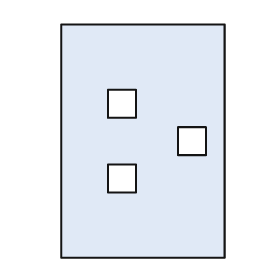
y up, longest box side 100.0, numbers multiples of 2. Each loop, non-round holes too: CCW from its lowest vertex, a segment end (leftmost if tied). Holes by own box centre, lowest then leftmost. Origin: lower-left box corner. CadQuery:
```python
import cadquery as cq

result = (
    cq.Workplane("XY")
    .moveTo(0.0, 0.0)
    .lineTo(70.0, 0.0)
    .lineTo(70.0, 100.0)
    .lineTo(0.0, 100.0)
    .close()
    .moveTo(20.0, 28.0)
    .lineTo(32.0, 28.0)
    .lineTo(32.0, 40.0)
    .lineTo(20.0, 40.0)
    .close()
    .moveTo(50.0, 44.0)
    .lineTo(62.0, 44.0)
    .lineTo(62.0, 56.0)
    .lineTo(50.0, 56.0)
    .close()
    .moveTo(20.0, 60.0)
    .lineTo(32.0, 60.0)
    .lineTo(32.0, 72.0)
    .lineTo(20.0, 72.0)
    .close()
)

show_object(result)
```